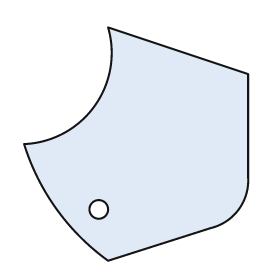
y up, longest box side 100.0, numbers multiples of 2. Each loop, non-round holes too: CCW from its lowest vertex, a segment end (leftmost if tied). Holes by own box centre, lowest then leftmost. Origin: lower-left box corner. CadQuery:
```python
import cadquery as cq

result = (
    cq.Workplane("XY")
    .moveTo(36.0, 0.0)
    .lineTo(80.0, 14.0)
    .threePointArc((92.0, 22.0), (96.0, 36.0))
    .lineTo(96.0, 80.0)
    .lineTo(36.0, 100.0)
    .threePointArc((30.0, 66.0), (0.0, 50.0))
    .threePointArc((14.0, 22.0), (36.0, 0.0))
    .close()
    .moveTo(32.0, 22.0)
    .circle(4.0)
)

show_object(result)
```